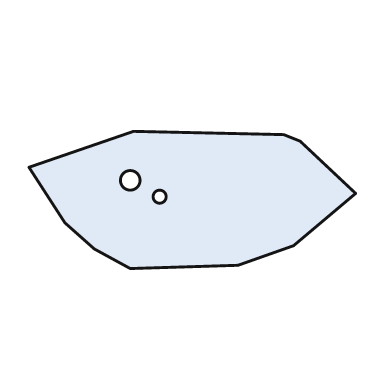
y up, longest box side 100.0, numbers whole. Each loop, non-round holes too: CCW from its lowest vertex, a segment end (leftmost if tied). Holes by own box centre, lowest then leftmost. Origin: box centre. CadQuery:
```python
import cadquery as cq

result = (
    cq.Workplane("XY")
    .moveTo(-19.0, -21.0)
    .lineTo(14.0, -20.0)
    .lineTo(31.0, -14.0)
    .lineTo(50.0, 2.0)
    .lineTo(33.0, 18.0)
    .lineTo(28.0, 20.0)
    .lineTo(-18.0, 21.0)
    .lineTo(-50.0, 10.0)
    .lineTo(-39.0, -7.0)
    .lineTo(-30.0, -15.0)
    .close()
    .moveTo(-10.0, 1.0)
    .circle(2.0)
    .moveTo(-19.0, 6.0)
    .circle(3.0)
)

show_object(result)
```